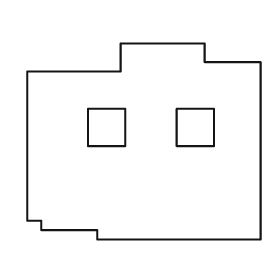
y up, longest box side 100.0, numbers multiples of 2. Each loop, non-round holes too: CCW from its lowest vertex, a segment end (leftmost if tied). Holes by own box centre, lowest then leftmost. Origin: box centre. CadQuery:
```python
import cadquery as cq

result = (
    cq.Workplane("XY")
    .moveTo(-20.0, -42.0)
    .lineTo(50.0, -42.0)
    .lineTo(50.0, 34.0)
    .lineTo(26.0, 34.0)
    .lineTo(26.0, 42.0)
    .lineTo(-10.0, 42.0)
    .lineTo(-10.0, 30.0)
    .lineTo(-50.0, 30.0)
    .lineTo(-50.0, -34.0)
    .lineTo(-44.0, -34.0)
    .lineTo(-44.0, -38.0)
    .lineTo(-20.0, -38.0)
    .close()
    .moveTo(-24.0, -2.0)
    .lineTo(-8.0, -2.0)
    .lineTo(-8.0, 14.0)
    .lineTo(-24.0, 14.0)
    .close()
    .moveTo(14.0, -2.0)
    .lineTo(30.0, -2.0)
    .lineTo(30.0, 14.0)
    .lineTo(14.0, 14.0)
    .close()
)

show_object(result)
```